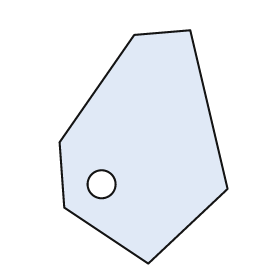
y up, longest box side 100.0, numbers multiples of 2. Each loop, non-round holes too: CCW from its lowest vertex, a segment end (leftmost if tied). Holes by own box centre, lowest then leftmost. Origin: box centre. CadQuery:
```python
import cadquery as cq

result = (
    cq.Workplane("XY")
    .moveTo(2.0, -50.0)
    .lineTo(36.0, -18.0)
    .lineTo(20.0, 50.0)
    .lineTo(-4.0, 48.0)
    .lineTo(-36.0, 2.0)
    .lineTo(-34.0, -26.0)
    .close()
    .moveTo(-18.0, -16.0)
    .circle(6.0)
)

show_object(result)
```